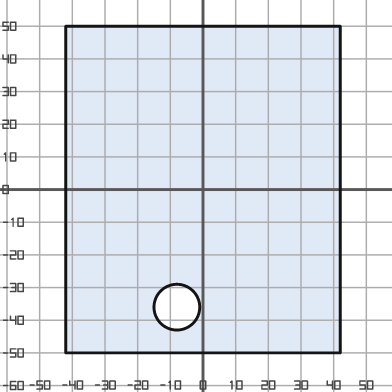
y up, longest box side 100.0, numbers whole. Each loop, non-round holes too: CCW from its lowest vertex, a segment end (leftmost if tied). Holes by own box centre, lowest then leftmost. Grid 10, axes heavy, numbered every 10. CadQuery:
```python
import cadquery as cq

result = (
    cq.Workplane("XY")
    .moveTo(-42.0, -50.0)
    .lineTo(42.0, -50.0)
    .lineTo(42.0, 50.0)
    .lineTo(-42.0, 50.0)
    .close()
    .moveTo(-8.0, -36.0)
    .circle(7.0)
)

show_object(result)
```